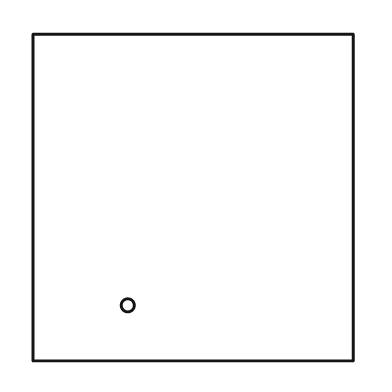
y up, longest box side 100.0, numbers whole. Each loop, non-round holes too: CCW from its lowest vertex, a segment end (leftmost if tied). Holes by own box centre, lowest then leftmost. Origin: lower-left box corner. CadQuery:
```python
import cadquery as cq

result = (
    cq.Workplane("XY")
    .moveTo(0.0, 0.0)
    .lineTo(98.0, 0.0)
    .lineTo(98.0, 100.0)
    .lineTo(0.0, 100.0)
    .close()
    .moveTo(29.0, 17.0)
    .circle(2.0)
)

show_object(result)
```